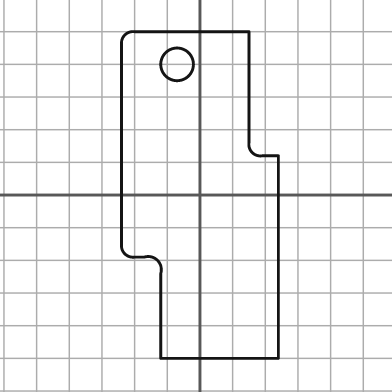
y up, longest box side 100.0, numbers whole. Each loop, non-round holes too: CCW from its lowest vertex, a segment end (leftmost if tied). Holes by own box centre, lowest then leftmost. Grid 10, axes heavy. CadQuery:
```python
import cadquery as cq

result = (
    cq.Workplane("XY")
    .moveTo(-12.0, -50.0)
    .lineTo(24.0, -50.0)
    .lineTo(24.0, 12.0)
    .lineTo(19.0, 12.0)
    .threePointArc((16.0, 13.0), (15.0, 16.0))
    .lineTo(15.0, 50.0)
    .lineTo(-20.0, 50.0)
    .threePointArc((-23.0, 49.0), (-24.0, 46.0))
    .lineTo(-24.0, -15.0)
    .threePointArc((-23.0, -18.0), (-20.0, -19.0))
    .lineTo(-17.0, -19.0)
    .threePointArc((-13.0, -20.0), (-12.0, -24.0))
    .close()
    .moveTo(-7.0, 40.0)
    .circle(5.0)
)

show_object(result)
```